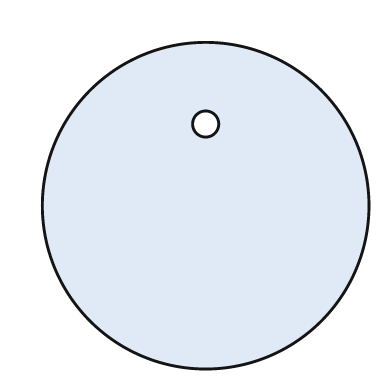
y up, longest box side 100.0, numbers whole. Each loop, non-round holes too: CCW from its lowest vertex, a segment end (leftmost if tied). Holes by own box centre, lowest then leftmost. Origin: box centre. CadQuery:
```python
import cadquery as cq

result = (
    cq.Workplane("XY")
    .moveTo(0.0, 0.0)
    .circle(50.0)
    .moveTo(0.0, 25.0)
    .circle(4.0)
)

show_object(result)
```